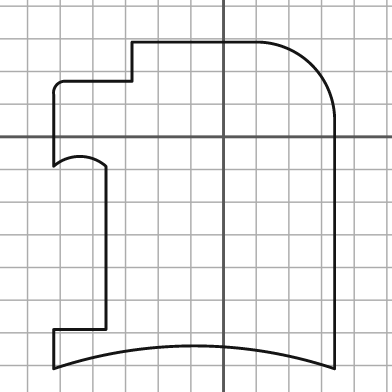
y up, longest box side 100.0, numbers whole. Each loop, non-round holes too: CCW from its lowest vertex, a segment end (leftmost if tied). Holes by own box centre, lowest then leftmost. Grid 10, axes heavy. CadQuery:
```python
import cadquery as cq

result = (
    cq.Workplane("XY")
    .moveTo(-52.0, -71.0)
    .threePointArc((-9.0, -64.0), (34.0, -71.0))
    .lineTo(34.0, 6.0)
    .threePointArc((27.0, 22.0), (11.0, 29.0))
    .lineTo(-28.0, 29.0)
    .lineTo(-28.0, 17.0)
    .lineTo(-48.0, 17.0)
    .threePointArc((-51.0, 16.0), (-52.0, 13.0))
    .lineTo(-52.0, -9.0)
    .threePointArc((-44.0, -6.0), (-36.0, -9.0))
    .lineTo(-36.0, -59.0)
    .lineTo(-52.0, -59.0)
    .close()
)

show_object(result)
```